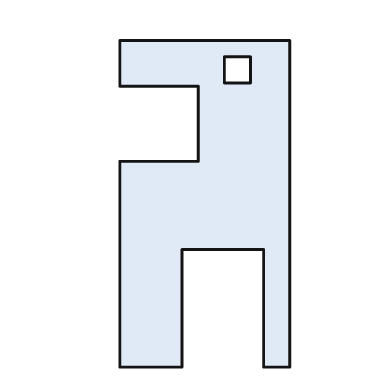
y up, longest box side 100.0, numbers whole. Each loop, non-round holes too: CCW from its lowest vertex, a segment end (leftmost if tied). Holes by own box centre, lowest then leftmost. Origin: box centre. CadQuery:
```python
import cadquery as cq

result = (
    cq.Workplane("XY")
    .moveTo(-26.0, -50.0)
    .lineTo(-7.0, -50.0)
    .lineTo(-7.0, -14.0)
    .lineTo(18.0, -14.0)
    .lineTo(18.0, -50.0)
    .lineTo(26.0, -50.0)
    .lineTo(26.0, 50.0)
    .lineTo(-26.0, 50.0)
    .lineTo(-26.0, 36.0)
    .lineTo(-2.0, 36.0)
    .lineTo(-2.0, 13.0)
    .lineTo(-26.0, 13.0)
    .close()
    .moveTo(6.0, 37.0)
    .lineTo(14.0, 37.0)
    .lineTo(14.0, 45.0)
    .lineTo(6.0, 45.0)
    .close()
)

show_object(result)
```